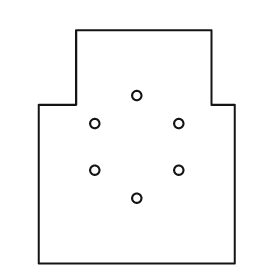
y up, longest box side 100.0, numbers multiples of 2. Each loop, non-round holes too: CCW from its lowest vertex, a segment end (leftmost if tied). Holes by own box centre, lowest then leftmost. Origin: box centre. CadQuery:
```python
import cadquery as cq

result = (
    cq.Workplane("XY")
    .moveTo(-42.0, -50.0)
    .lineTo(42.0, -50.0)
    .lineTo(42.0, 18.0)
    .lineTo(32.0, 18.0)
    .lineTo(32.0, 50.0)
    .lineTo(-26.0, 50.0)
    .lineTo(-26.0, 18.0)
    .lineTo(-42.0, 18.0)
    .close()
    .moveTo(0.0, -22.0)
    .circle(2.0)
    .moveTo(-18.0, -10.0)
    .circle(2.0)
    .moveTo(18.0, -10.0)
    .circle(2.0)
    .moveTo(-18.0, 10.0)
    .circle(2.0)
    .moveTo(18.0, 10.0)
    .circle(2.0)
    .moveTo(0.0, 22.0)
    .circle(2.0)
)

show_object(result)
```